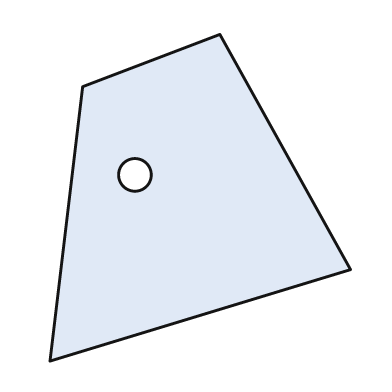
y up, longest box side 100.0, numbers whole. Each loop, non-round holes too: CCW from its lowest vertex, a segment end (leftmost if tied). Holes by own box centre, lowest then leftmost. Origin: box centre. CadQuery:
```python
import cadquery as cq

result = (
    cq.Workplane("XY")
    .moveTo(-46.0, -50.0)
    .lineTo(46.0, -22.0)
    .lineTo(6.0, 50.0)
    .lineTo(-36.0, 34.0)
    .close()
    .moveTo(-20.0, 7.0)
    .circle(5.0)
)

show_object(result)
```